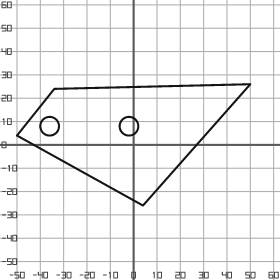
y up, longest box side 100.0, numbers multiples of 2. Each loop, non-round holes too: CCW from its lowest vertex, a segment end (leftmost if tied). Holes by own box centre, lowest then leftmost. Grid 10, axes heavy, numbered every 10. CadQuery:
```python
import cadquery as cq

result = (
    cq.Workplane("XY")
    .moveTo(4.0, -26.0)
    .lineTo(50.0, 26.0)
    .lineTo(-34.0, 24.0)
    .lineTo(-50.0, 4.0)
    .close()
    .moveTo(-36.0, 8.0)
    .circle(4.0)
    .moveTo(-2.0, 8.0)
    .circle(4.0)
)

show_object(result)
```